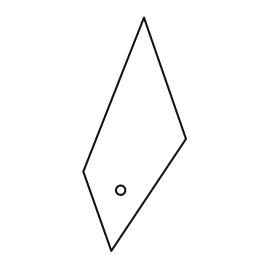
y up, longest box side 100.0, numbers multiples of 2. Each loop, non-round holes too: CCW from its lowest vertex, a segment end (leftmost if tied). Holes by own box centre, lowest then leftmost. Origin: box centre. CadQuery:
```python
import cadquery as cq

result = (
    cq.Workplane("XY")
    .moveTo(-10.0, -50.0)
    .lineTo(22.0, -2.0)
    .lineTo(4.0, 50.0)
    .lineTo(-22.0, -16.0)
    .close()
    .moveTo(-6.0, -24.0)
    .circle(2.0)
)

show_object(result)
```